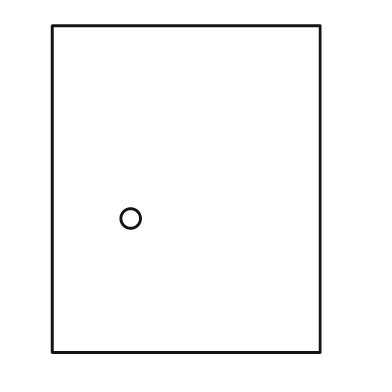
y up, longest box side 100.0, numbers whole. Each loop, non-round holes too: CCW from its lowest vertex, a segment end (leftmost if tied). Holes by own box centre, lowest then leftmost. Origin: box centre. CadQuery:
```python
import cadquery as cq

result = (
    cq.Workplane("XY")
    .moveTo(-41.0, -50.0)
    .lineTo(41.0, -50.0)
    .lineTo(41.0, 50.0)
    .lineTo(-41.0, 50.0)
    .close()
    .moveTo(-17.0, -9.0)
    .circle(3.0)
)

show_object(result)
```